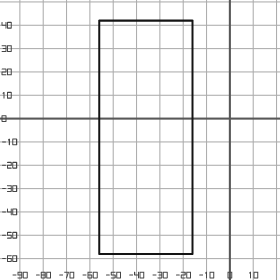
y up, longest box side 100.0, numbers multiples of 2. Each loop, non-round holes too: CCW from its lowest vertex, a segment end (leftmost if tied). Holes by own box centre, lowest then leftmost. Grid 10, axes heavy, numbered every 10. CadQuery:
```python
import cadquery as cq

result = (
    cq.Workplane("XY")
    .moveTo(-56.0, -58.0)
    .lineTo(-16.0, -58.0)
    .lineTo(-16.0, 42.0)
    .lineTo(-56.0, 42.0)
    .close()
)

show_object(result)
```